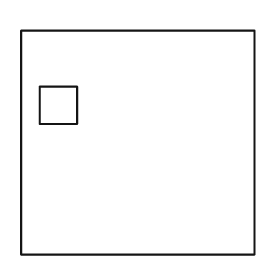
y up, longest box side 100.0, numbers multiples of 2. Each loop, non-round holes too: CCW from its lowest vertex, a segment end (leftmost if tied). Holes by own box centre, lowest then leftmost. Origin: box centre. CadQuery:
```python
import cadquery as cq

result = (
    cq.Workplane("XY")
    .moveTo(-50.0, -48.0)
    .lineTo(50.0, -48.0)
    .lineTo(50.0, 48.0)
    .lineTo(-50.0, 48.0)
    .close()
    .moveTo(-42.0, 8.0)
    .lineTo(-26.0, 8.0)
    .lineTo(-26.0, 24.0)
    .lineTo(-42.0, 24.0)
    .close()
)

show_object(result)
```